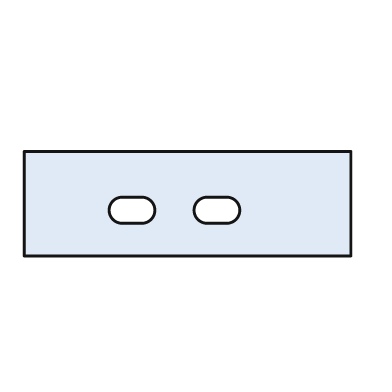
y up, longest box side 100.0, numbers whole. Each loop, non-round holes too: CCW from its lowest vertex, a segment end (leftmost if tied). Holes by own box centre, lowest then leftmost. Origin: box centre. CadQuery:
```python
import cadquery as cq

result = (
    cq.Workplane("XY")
    .moveTo(-50.0, -16.0)
    .lineTo(50.0, -16.0)
    .lineTo(50.0, 16.0)
    .lineTo(-50.0, 16.0)
    .close()
    .moveTo(-20.0, -6.0)
    .lineTo(-14.0, -6.0)
    .threePointArc((-10.0, -2.0), (-14.0, 2.0))
    .lineTo(-20.0, 2.0)
    .threePointArc((-24.0, -2.0), (-20.0, -6.0))
    .close()
    .moveTo(6.0, -6.0)
    .lineTo(12.0, -6.0)
    .threePointArc((16.0, -2.0), (12.0, 2.0))
    .lineTo(6.0, 2.0)
    .threePointArc((2.0, -2.0), (6.0, -6.0))
    .close()
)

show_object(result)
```